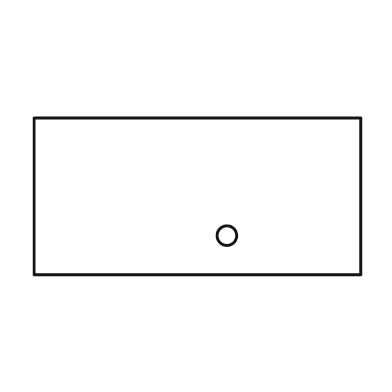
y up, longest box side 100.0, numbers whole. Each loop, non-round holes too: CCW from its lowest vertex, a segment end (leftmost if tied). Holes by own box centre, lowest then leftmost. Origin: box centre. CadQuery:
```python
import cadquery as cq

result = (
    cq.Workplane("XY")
    .moveTo(-50.0, -24.0)
    .lineTo(50.0, -24.0)
    .lineTo(50.0, 24.0)
    .lineTo(-50.0, 24.0)
    .close()
    .moveTo(9.0, -12.0)
    .circle(3.0)
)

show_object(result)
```